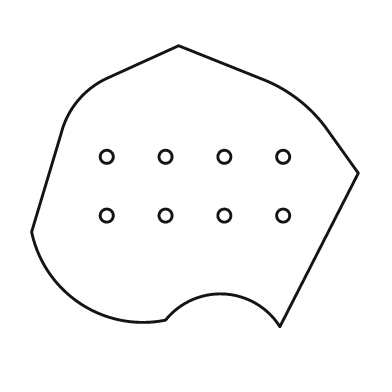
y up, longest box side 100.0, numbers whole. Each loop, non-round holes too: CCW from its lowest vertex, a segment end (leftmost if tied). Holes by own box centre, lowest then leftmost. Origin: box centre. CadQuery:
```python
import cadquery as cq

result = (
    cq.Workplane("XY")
    .moveTo(26.0, -43.0)
    .lineTo(50.0, 4.0)
    .lineTo(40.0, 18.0)
    .threePointArc((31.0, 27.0), (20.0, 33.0))
    .lineTo(-5.0, 43.0)
    .lineTo(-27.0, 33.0)
    .threePointArc((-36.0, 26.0), (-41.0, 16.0))
    .lineTo(-50.0, -14.0)
    .threePointArc((-35.0, -36.0), (-9.0, -41.0))
    .threePointArc((9.0, -33.0), (26.0, -43.0))
    .close()
    .moveTo(-27.0, -9.0)
    .circle(2.0)
    .moveTo(-9.0, -9.0)
    .circle(2.0)
    .moveTo(9.0, -9.0)
    .circle(2.0)
    .moveTo(27.0, -9.0)
    .circle(2.0)
    .moveTo(-27.0, 9.0)
    .circle(2.0)
    .moveTo(-9.0, 9.0)
    .circle(2.0)
    .moveTo(9.0, 9.0)
    .circle(2.0)
    .moveTo(27.0, 9.0)
    .circle(2.0)
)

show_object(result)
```